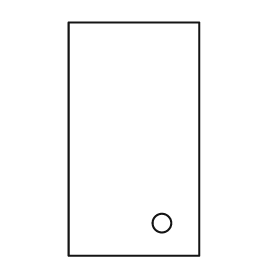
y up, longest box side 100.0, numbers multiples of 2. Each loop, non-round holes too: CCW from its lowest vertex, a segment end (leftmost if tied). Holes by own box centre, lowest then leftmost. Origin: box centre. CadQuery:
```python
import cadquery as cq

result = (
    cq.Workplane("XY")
    .moveTo(-28.0, -50.0)
    .lineTo(28.0, -50.0)
    .lineTo(28.0, 50.0)
    .lineTo(-28.0, 50.0)
    .close()
    .moveTo(12.0, -36.0)
    .circle(4.0)
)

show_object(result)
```